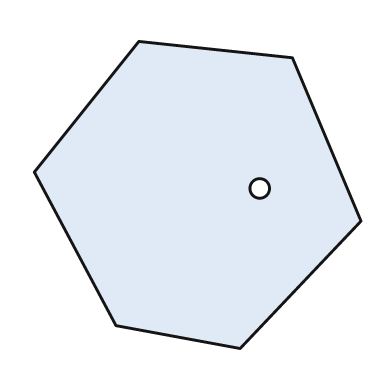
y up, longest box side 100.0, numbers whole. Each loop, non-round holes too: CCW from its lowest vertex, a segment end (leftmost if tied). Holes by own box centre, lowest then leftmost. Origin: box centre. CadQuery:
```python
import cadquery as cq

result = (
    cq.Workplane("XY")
    .moveTo(13.0, -47.0)
    .lineTo(50.0, -8.0)
    .lineTo(29.0, 42.0)
    .lineTo(-18.0, 47.0)
    .lineTo(-50.0, 7.0)
    .lineTo(-25.0, -40.0)
    .close()
    .moveTo(19.0, 2.0)
    .circle(3.0)
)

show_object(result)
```